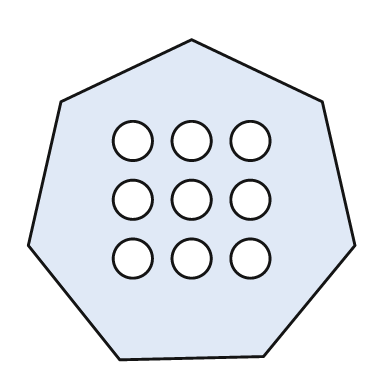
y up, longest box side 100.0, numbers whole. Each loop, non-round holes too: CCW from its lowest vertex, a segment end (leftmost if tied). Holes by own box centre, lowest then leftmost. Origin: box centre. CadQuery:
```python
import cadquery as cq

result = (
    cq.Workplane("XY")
    .moveTo(-22.0, -49.0)
    .lineTo(22.0, -48.0)
    .lineTo(50.0, -14.0)
    .lineTo(40.0, 30.0)
    .lineTo(0.0, 49.0)
    .lineTo(-40.0, 30.0)
    .lineTo(-50.0, -14.0)
    .close()
    .moveTo(-18.0, -18.0)
    .circle(6.0)
    .moveTo(0.0, -18.0)
    .circle(6.0)
    .moveTo(18.0, -18.0)
    .circle(6.0)
    .moveTo(-18.0, 0.0)
    .circle(6.0)
    .moveTo(0.0, 0.0)
    .circle(6.0)
    .moveTo(18.0, 0.0)
    .circle(6.0)
    .moveTo(-18.0, 18.0)
    .circle(6.0)
    .moveTo(0.0, 18.0)
    .circle(6.0)
    .moveTo(18.0, 18.0)
    .circle(6.0)
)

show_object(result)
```